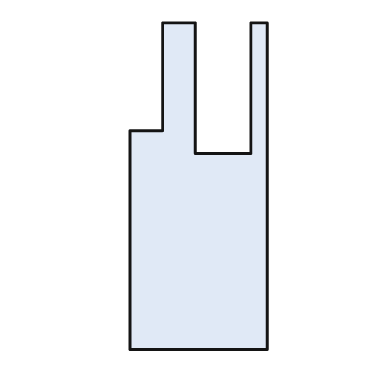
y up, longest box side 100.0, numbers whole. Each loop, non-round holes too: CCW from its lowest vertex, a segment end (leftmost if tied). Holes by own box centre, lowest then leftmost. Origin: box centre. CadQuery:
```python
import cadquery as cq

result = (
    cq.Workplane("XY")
    .moveTo(-21.0, -50.0)
    .lineTo(21.0, -50.0)
    .lineTo(21.0, 50.0)
    .lineTo(16.0, 50.0)
    .lineTo(16.0, 10.0)
    .lineTo(-1.0, 10.0)
    .lineTo(-1.0, 50.0)
    .lineTo(-11.0, 50.0)
    .lineTo(-11.0, 17.0)
    .lineTo(-21.0, 17.0)
    .close()
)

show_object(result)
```